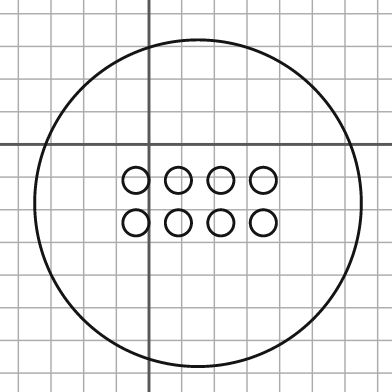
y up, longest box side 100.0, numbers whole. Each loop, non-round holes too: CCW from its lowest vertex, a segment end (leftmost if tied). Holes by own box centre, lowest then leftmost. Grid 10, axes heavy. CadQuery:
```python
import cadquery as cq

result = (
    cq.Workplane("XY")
    .moveTo(15.0, -18.0)
    .circle(50.0)
    .moveTo(-4.0, -24.0)
    .circle(4.0)
    .moveTo(9.0, -24.0)
    .circle(4.0)
    .moveTo(22.0, -24.0)
    .circle(4.0)
    .moveTo(35.0, -24.0)
    .circle(4.0)
    .moveTo(-4.0, -11.0)
    .circle(4.0)
    .moveTo(9.0, -11.0)
    .circle(4.0)
    .moveTo(22.0, -11.0)
    .circle(4.0)
    .moveTo(35.0, -11.0)
    .circle(4.0)
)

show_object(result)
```